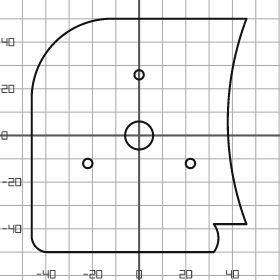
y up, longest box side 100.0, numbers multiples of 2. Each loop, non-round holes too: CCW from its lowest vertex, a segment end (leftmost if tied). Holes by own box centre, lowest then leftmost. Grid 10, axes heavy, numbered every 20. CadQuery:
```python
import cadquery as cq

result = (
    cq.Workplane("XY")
    .moveTo(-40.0, -50.0)
    .lineTo(32.0, -50.0)
    .threePointArc((34.0, -44.0), (32.0, -38.0))
    .lineTo(46.0, -38.0)
    .threePointArc((38.0, 6.0), (46.0, 50.0))
    .lineTo(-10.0, 50.0)
    .threePointArc((-36.0, 40.0), (-46.0, 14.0))
    .lineTo(-46.0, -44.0)
    .threePointArc((-44.0, -48.0), (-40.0, -50.0))
    .close()
    .moveTo(-22.0, -12.0)
    .circle(2.0)
    .moveTo(22.0, -12.0)
    .circle(2.0)
    .moveTo(0.0, 0.0)
    .circle(6.0)
    .moveTo(0.0, 26.0)
    .circle(2.0)
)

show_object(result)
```